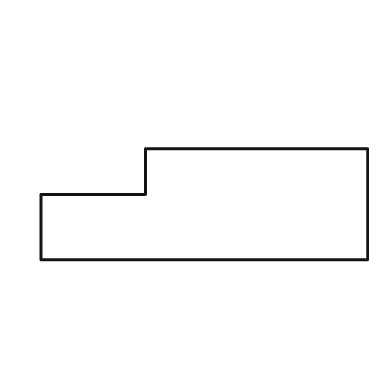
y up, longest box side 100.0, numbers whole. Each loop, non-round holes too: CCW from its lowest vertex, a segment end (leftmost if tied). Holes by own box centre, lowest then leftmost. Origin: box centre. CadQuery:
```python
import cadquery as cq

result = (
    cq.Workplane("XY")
    .moveTo(-50.0, -17.0)
    .lineTo(50.0, -17.0)
    .lineTo(50.0, 17.0)
    .lineTo(-18.0, 17.0)
    .lineTo(-18.0, 3.0)
    .lineTo(-50.0, 3.0)
    .close()
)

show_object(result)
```